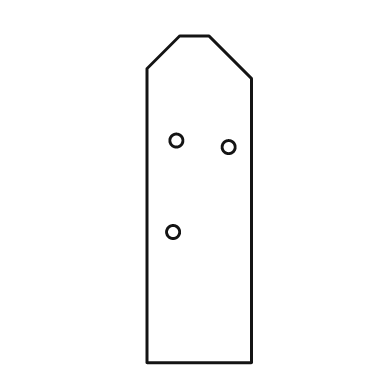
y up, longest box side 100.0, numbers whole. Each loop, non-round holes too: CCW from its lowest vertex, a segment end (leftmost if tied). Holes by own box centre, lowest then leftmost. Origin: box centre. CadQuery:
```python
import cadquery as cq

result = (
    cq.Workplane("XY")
    .moveTo(-16.0, -50.0)
    .lineTo(16.0, -50.0)
    .lineTo(16.0, 37.0)
    .lineTo(3.0, 50.0)
    .lineTo(-6.0, 50.0)
    .lineTo(-16.0, 40.0)
    .close()
    .moveTo(-8.0, -10.0)
    .circle(2.0)
    .moveTo(9.0, 16.0)
    .circle(2.0)
    .moveTo(-7.0, 18.0)
    .circle(2.0)
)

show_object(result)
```